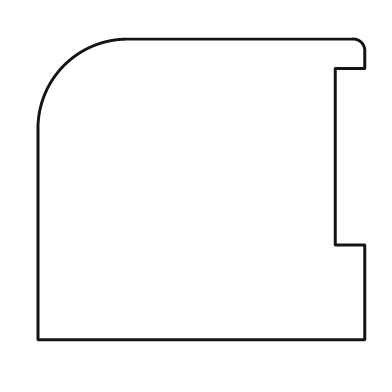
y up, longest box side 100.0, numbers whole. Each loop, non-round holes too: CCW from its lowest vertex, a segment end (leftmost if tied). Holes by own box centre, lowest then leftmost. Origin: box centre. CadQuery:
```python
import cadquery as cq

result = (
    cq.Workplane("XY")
    .moveTo(-50.0, -46.0)
    .lineTo(50.0, -46.0)
    .lineTo(50.0, -17.0)
    .lineTo(41.0, -17.0)
    .lineTo(41.0, 37.0)
    .lineTo(50.0, 37.0)
    .lineTo(50.0, 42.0)
    .threePointArc((49.0, 45.0), (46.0, 46.0))
    .lineTo(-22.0, 46.0)
    .threePointArc((-42.0, 38.0), (-50.0, 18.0))
    .close()
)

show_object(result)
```